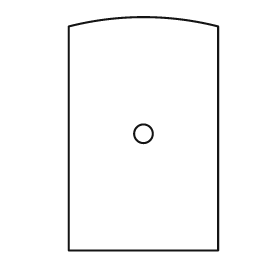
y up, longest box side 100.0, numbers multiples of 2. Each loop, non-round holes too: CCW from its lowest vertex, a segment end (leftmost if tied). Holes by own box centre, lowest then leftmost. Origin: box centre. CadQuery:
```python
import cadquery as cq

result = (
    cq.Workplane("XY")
    .moveTo(-32.0, -50.0)
    .lineTo(32.0, -50.0)
    .lineTo(32.0, 46.0)
    .threePointArc((0.0, 50.0), (-32.0, 46.0))
    .close()
    .moveTo(0.0, 0.0)
    .circle(4.0)
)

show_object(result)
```